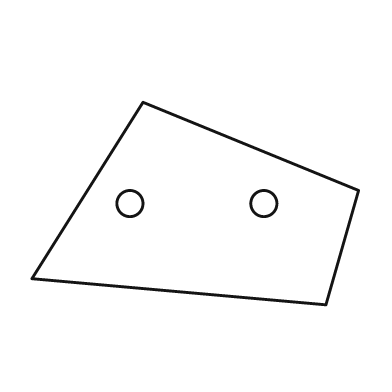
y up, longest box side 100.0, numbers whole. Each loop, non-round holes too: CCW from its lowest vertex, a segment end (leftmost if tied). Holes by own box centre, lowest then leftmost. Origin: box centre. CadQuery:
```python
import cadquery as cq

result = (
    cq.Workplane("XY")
    .moveTo(40.0, -31.0)
    .lineTo(50.0, 4.0)
    .lineTo(-16.0, 31.0)
    .lineTo(-50.0, -23.0)
    .close()
    .moveTo(-20.0, 0.0)
    .circle(4.0)
    .moveTo(21.0, 0.0)
    .circle(4.0)
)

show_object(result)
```